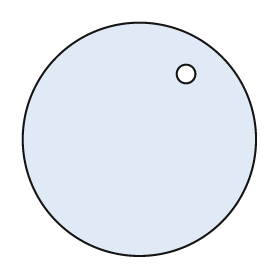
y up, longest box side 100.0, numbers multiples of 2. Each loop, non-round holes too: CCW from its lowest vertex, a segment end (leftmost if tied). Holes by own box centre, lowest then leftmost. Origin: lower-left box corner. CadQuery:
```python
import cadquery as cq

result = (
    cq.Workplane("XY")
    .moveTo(50.0, 50.0)
    .circle(50.0)
    .moveTo(70.0, 78.0)
    .circle(4.0)
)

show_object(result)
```